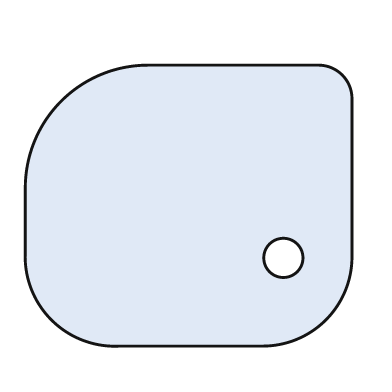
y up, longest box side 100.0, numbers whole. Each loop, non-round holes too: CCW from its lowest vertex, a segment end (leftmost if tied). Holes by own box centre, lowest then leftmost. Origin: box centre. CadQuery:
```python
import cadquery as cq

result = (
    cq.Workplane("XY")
    .moveTo(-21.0, -43.0)
    .lineTo(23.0, -43.0)
    .threePointArc((42.0, -35.0), (50.0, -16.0))
    .lineTo(50.0, 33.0)
    .threePointArc((47.0, 40.0), (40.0, 43.0))
    .lineTo(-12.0, 43.0)
    .threePointArc((-39.0, 32.0), (-50.0, 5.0))
    .lineTo(-50.0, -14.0)
    .threePointArc((-42.0, -35.0), (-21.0, -43.0))
    .close()
    .moveTo(29.0, -16.0)
    .circle(6.0)
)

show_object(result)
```